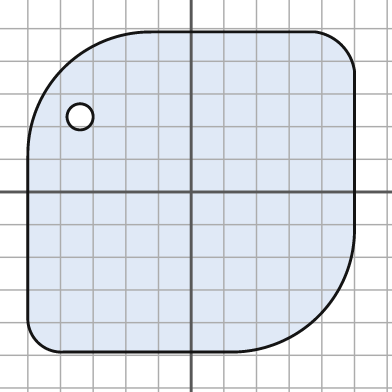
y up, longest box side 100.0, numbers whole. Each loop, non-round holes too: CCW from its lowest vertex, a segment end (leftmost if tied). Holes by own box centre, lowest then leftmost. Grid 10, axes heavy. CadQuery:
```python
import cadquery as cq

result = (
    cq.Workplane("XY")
    .moveTo(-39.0, -49.0)
    .lineTo(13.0, -49.0)
    .threePointArc((39.0, -38.0), (50.0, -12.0))
    .lineTo(50.0, 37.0)
    .threePointArc((46.0, 45.0), (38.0, 49.0))
    .lineTo(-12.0, 49.0)
    .threePointArc((-39.0, 38.0), (-50.0, 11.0))
    .lineTo(-50.0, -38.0)
    .threePointArc((-47.0, -46.0), (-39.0, -49.0))
    .close()
    .moveTo(-34.0, 23.0)
    .circle(4.0)
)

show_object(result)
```